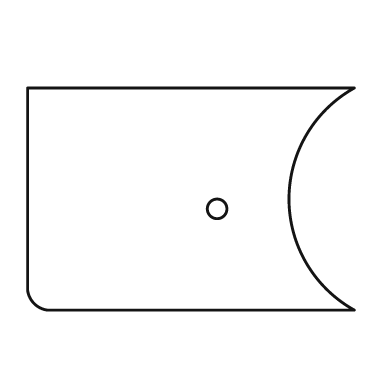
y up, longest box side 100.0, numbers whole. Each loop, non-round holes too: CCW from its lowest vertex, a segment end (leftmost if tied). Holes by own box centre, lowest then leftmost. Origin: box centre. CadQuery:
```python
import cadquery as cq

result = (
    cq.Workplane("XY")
    .moveTo(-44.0, -34.0)
    .lineTo(50.0, -34.0)
    .threePointArc((30.0, 0.0), (50.0, 34.0))
    .lineTo(-50.0, 34.0)
    .lineTo(-50.0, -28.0)
    .threePointArc((-48.0, -32.0), (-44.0, -34.0))
    .close()
    .moveTo(8.0, -3.0)
    .circle(3.0)
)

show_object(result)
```